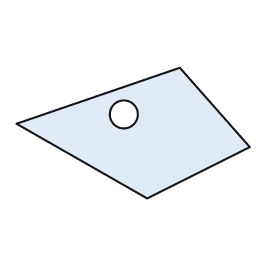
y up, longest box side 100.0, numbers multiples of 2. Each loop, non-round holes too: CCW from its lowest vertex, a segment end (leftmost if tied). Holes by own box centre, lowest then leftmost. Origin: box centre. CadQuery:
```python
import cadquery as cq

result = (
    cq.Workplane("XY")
    .moveTo(6.0, -28.0)
    .lineTo(50.0, -6.0)
    .lineTo(20.0, 28.0)
    .lineTo(-50.0, 4.0)
    .close()
    .moveTo(-4.0, 8.0)
    .circle(6.0)
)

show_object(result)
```